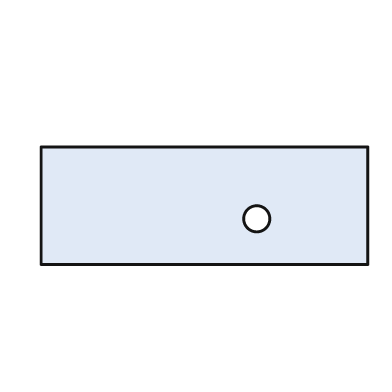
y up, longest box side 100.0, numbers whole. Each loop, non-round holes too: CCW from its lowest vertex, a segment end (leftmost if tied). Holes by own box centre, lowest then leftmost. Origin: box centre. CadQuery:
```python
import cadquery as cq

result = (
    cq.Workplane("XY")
    .moveTo(-50.0, -18.0)
    .lineTo(50.0, -18.0)
    .lineTo(50.0, 18.0)
    .lineTo(-50.0, 18.0)
    .close()
    .moveTo(16.0, -4.0)
    .circle(4.0)
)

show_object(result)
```